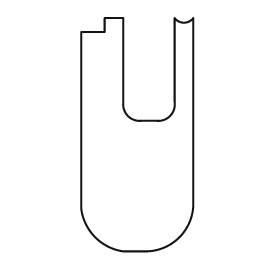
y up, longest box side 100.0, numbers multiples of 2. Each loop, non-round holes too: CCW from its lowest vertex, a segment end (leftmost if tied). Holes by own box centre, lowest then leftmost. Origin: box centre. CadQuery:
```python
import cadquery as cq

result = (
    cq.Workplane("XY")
    .moveTo(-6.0, -50.0)
    .lineTo(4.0, -50.0)
    .threePointArc((18.0, -44.0), (24.0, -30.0))
    .lineTo(24.0, 50.0)
    .threePointArc((20.0, 48.0), (16.0, 50.0))
    .lineTo(16.0, 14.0)
    .threePointArc((14.0, 8.0), (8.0, 6.0))
    .lineTo(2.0, 6.0)
    .threePointArc((-4.0, 8.0), (-6.0, 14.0))
    .lineTo(-6.0, 50.0)
    .lineTo(-14.0, 50.0)
    .lineTo(-14.0, 44.0)
    .lineTo(-24.0, 44.0)
    .lineTo(-24.0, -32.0)
    .threePointArc((-18.0, -44.0), (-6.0, -50.0))
    .close()
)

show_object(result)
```